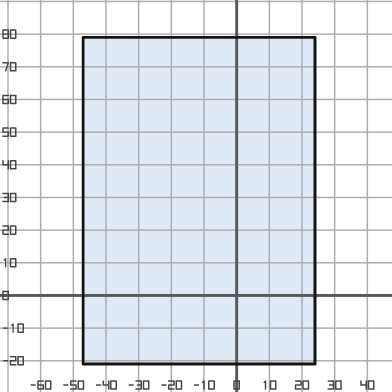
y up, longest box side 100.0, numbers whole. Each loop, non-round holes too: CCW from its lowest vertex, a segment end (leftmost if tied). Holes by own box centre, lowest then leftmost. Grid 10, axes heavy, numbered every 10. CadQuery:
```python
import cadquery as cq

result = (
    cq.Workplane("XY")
    .moveTo(-47.0, -21.0)
    .lineTo(24.0, -21.0)
    .lineTo(24.0, 79.0)
    .lineTo(-47.0, 79.0)
    .close()
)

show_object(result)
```